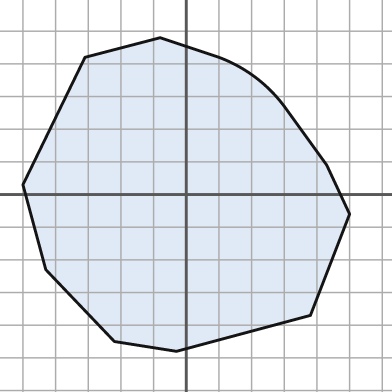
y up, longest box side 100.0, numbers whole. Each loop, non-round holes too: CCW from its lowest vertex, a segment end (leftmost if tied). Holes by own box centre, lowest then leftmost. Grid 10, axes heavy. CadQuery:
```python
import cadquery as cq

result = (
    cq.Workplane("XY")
    .moveTo(-3.0, -48.0)
    .lineTo(38.0, -37.0)
    .lineTo(50.0, -6.0)
    .lineTo(43.0, 9.0)
    .lineTo(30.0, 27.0)
    .threePointArc((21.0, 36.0), (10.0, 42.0))
    .lineTo(-8.0, 48.0)
    .lineTo(-31.0, 42.0)
    .lineTo(-50.0, 3.0)
    .lineTo(-43.0, -23.0)
    .lineTo(-22.0, -45.0)
    .close()
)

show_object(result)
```